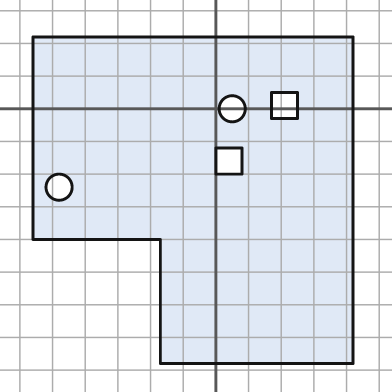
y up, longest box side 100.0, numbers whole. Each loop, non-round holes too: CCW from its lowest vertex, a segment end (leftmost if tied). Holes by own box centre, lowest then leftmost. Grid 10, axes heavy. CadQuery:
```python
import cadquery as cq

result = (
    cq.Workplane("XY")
    .moveTo(-17.0, -78.0)
    .lineTo(42.0, -78.0)
    .lineTo(42.0, 22.0)
    .lineTo(-56.0, 22.0)
    .lineTo(-56.0, -40.0)
    .lineTo(-17.0, -40.0)
    .close()
    .moveTo(-48.0, -24.0)
    .circle(4.0)
    .moveTo(0.0, -20.0)
    .lineTo(8.0, -20.0)
    .lineTo(8.0, -12.0)
    .lineTo(0.0, -12.0)
    .close()
    .moveTo(5.0, 0.0)
    .circle(4.0)
    .moveTo(17.0, -3.0)
    .lineTo(25.0, -3.0)
    .lineTo(25.0, 5.0)
    .lineTo(17.0, 5.0)
    .close()
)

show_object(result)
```